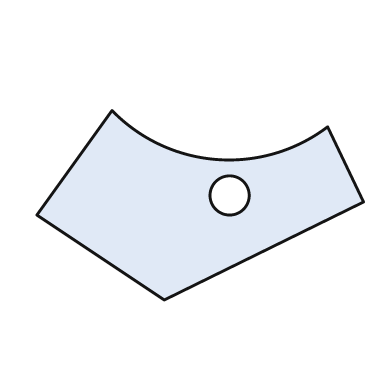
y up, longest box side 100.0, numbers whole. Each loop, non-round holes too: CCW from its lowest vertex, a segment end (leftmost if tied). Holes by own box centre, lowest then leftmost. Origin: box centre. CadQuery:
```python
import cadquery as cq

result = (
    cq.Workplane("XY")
    .moveTo(-11.0, -29.0)
    .lineTo(50.0, 1.0)
    .lineTo(39.0, 24.0)
    .threePointArc((5.0, 14.0), (-27.0, 29.0))
    .lineTo(-50.0, -3.0)
    .close()
    .moveTo(9.0, 3.0)
    .circle(6.0)
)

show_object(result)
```